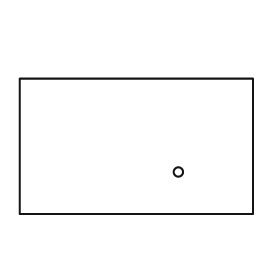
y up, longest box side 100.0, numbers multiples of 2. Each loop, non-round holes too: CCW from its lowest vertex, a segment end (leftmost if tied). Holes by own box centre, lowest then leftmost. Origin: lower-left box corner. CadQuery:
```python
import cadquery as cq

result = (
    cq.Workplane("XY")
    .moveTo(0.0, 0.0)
    .lineTo(100.0, 0.0)
    .lineTo(100.0, 58.0)
    .lineTo(0.0, 58.0)
    .close()
    .moveTo(68.0, 18.0)
    .circle(2.0)
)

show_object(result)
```